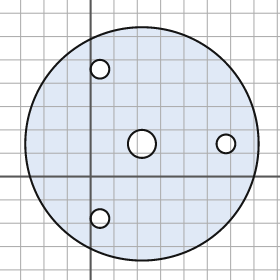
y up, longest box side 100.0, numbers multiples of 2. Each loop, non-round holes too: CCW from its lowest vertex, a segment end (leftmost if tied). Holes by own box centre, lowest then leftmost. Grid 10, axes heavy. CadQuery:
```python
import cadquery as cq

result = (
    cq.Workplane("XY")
    .moveTo(22.0, 14.0)
    .circle(50.0)
    .moveTo(4.0, -18.0)
    .circle(4.0)
    .moveTo(22.0, 14.0)
    .circle(6.0)
    .moveTo(58.0, 14.0)
    .circle(4.0)
    .moveTo(4.0, 46.0)
    .circle(4.0)
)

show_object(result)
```